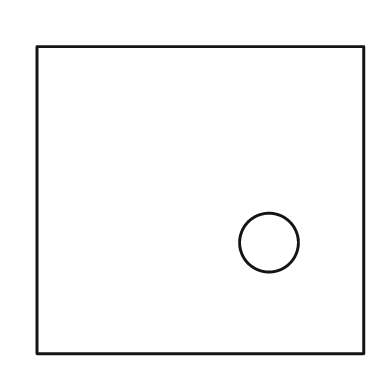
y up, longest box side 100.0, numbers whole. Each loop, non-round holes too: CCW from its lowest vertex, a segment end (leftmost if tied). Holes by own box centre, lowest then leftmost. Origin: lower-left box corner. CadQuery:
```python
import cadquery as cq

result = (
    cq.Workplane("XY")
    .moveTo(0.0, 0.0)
    .lineTo(100.0, 0.0)
    .lineTo(100.0, 94.0)
    .lineTo(0.0, 94.0)
    .close()
    .moveTo(71.0, 34.0)
    .circle(9.0)
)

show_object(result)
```